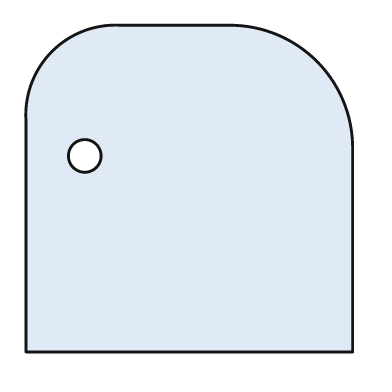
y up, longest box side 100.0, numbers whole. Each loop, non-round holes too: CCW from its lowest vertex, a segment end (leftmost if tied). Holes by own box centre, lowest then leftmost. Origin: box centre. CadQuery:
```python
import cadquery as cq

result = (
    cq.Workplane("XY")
    .moveTo(-50.0, -50.0)
    .lineTo(50.0, -50.0)
    .lineTo(50.0, 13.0)
    .threePointArc((39.0, 39.0), (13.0, 50.0))
    .lineTo(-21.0, 50.0)
    .threePointArc((-42.0, 42.0), (-50.0, 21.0))
    .close()
    .moveTo(-32.0, 10.0)
    .circle(5.0)
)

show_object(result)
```